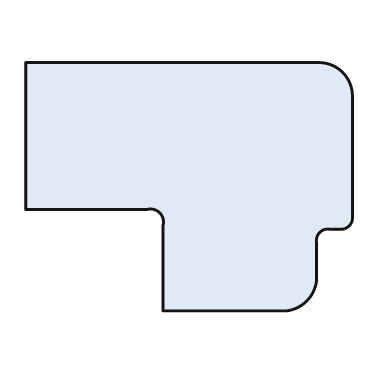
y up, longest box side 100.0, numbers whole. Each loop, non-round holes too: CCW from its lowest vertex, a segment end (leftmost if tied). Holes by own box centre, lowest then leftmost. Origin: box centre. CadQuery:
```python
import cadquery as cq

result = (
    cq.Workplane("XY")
    .moveTo(-8.0, -38.0)
    .lineTo(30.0, -38.0)
    .threePointArc((36.0, -35.0), (39.0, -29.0))
    .lineTo(39.0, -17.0)
    .threePointArc((40.0, -14.0), (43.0, -13.0))
    .lineTo(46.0, -13.0)
    .threePointArc((49.0, -12.0), (50.0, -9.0))
    .lineTo(50.0, 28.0)
    .threePointArc((47.0, 35.0), (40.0, 38.0))
    .lineTo(-50.0, 38.0)
    .lineTo(-50.0, -7.0)
    .lineTo(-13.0, -7.0)
    .threePointArc((-9.0, -8.0), (-8.0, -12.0))
    .close()
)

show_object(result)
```